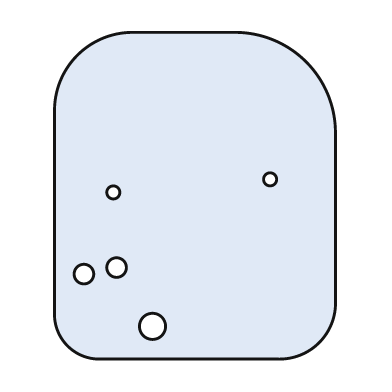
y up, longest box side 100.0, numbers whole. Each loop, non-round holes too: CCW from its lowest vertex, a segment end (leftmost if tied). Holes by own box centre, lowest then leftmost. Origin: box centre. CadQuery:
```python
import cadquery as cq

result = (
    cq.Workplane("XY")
    .moveTo(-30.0, -50.0)
    .lineTo(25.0, -50.0)
    .threePointArc((38.0, -45.0), (43.0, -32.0))
    .lineTo(43.0, 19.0)
    .threePointArc((34.0, 41.0), (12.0, 50.0))
    .lineTo(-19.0, 50.0)
    .threePointArc((-36.0, 43.0), (-43.0, 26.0))
    .lineTo(-43.0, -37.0)
    .threePointArc((-39.0, -46.0), (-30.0, -50.0))
    .close()
    .moveTo(-13.0, -40.0)
    .circle(4.0)
    .moveTo(-34.0, -24.0)
    .circle(3.0)
    .moveTo(-24.0, -22.0)
    .circle(3.0)
    .moveTo(-25.0, 1.0)
    .circle(2.0)
    .moveTo(23.0, 5.0)
    .circle(2.0)
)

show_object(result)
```